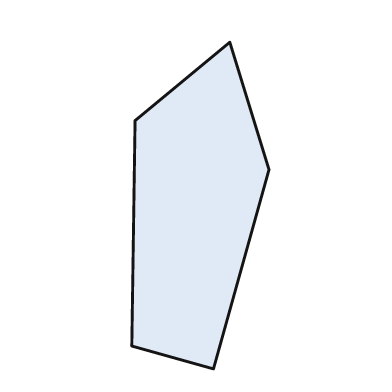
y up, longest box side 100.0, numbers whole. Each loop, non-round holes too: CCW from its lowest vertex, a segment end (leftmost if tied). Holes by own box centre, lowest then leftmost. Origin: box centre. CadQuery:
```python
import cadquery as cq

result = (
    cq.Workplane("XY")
    .moveTo(4.0, -50.0)
    .lineTo(21.0, 11.0)
    .lineTo(9.0, 50.0)
    .lineTo(-20.0, 26.0)
    .lineTo(-21.0, -43.0)
    .close()
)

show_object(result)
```